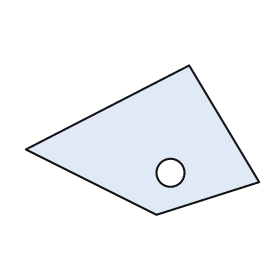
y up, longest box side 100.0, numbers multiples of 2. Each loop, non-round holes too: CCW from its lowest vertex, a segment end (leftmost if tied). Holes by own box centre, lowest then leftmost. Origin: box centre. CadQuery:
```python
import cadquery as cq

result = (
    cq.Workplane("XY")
    .moveTo(6.0, -32.0)
    .lineTo(50.0, -18.0)
    .lineTo(20.0, 32.0)
    .lineTo(-50.0, -4.0)
    .close()
    .moveTo(12.0, -14.0)
    .circle(6.0)
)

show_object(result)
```